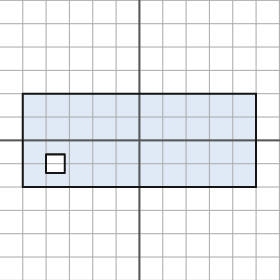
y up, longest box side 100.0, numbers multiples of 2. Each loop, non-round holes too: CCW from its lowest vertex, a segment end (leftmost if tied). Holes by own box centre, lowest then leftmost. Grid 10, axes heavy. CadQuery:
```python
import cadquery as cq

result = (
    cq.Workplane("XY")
    .moveTo(-50.0, -20.0)
    .lineTo(50.0, -20.0)
    .lineTo(50.0, 20.0)
    .lineTo(-50.0, 20.0)
    .close()
    .moveTo(-40.0, -14.0)
    .lineTo(-32.0, -14.0)
    .lineTo(-32.0, -6.0)
    .lineTo(-40.0, -6.0)
    .close()
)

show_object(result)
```